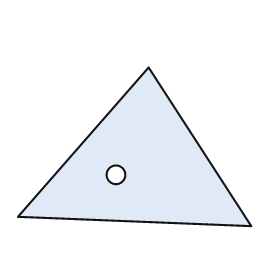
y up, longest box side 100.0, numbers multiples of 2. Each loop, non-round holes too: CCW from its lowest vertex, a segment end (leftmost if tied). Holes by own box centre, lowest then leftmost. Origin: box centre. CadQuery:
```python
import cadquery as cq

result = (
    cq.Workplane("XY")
    .moveTo(50.0, -34.0)
    .lineTo(6.0, 34.0)
    .lineTo(-50.0, -30.0)
    .close()
    .moveTo(-8.0, -12.0)
    .circle(4.0)
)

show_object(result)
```